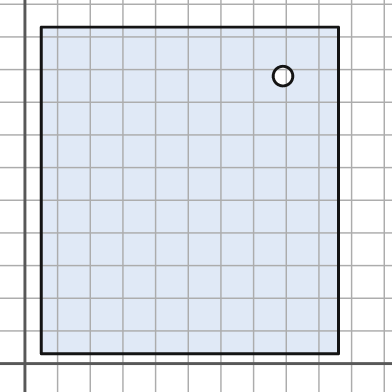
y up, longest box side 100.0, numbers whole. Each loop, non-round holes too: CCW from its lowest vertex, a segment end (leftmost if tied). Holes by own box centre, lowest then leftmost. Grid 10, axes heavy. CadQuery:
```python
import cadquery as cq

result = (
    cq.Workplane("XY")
    .moveTo(5.0, 3.0)
    .lineTo(96.0, 3.0)
    .lineTo(96.0, 103.0)
    .lineTo(5.0, 103.0)
    .close()
    .moveTo(79.0, 88.0)
    .circle(3.0)
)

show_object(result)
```